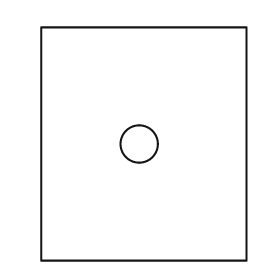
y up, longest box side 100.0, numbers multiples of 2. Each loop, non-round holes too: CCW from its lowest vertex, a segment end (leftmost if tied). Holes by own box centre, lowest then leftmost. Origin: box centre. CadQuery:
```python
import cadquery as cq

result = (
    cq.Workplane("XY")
    .moveTo(-44.0, -50.0)
    .lineTo(44.0, -50.0)
    .lineTo(44.0, 50.0)
    .lineTo(-44.0, 50.0)
    .close()
    .moveTo(-2.0, 0.0)
    .circle(8.0)
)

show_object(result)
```